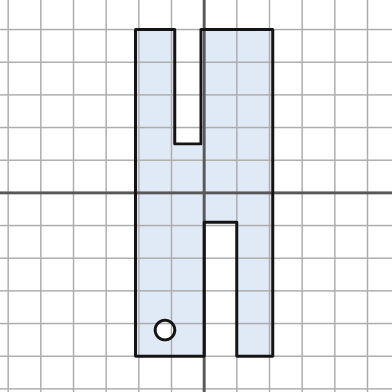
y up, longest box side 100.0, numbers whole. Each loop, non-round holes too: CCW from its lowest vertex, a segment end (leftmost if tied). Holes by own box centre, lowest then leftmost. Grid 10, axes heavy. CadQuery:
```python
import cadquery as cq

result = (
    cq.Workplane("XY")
    .moveTo(-21.0, -50.0)
    .lineTo(0.0, -50.0)
    .lineTo(0.0, -9.0)
    .lineTo(10.0, -9.0)
    .lineTo(10.0, -50.0)
    .lineTo(21.0, -50.0)
    .lineTo(21.0, 50.0)
    .lineTo(-1.0, 50.0)
    .lineTo(-1.0, 15.0)
    .lineTo(-9.0, 15.0)
    .lineTo(-9.0, 50.0)
    .lineTo(-21.0, 50.0)
    .close()
    .moveTo(-12.0, -42.0)
    .circle(3.0)
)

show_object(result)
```